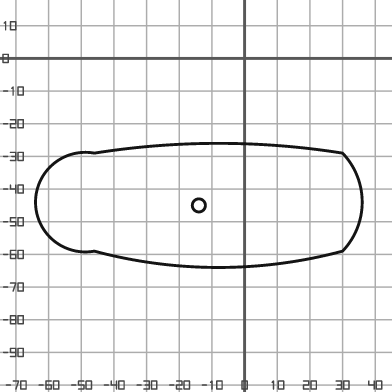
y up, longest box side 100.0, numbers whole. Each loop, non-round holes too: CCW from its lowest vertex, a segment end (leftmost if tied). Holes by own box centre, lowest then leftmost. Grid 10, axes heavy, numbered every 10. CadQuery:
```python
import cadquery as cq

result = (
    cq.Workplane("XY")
    .moveTo(-46.0, -59.0)
    .threePointArc((-8.0, -64.0), (30.0, -59.0))
    .threePointArc((36.0, -44.0), (30.0, -29.0))
    .threePointArc((-8.0, -26.0), (-46.0, -29.0))
    .threePointArc((-64.0, -44.0), (-46.0, -59.0))
    .close()
    .moveTo(-14.0, -45.0)
    .circle(2.0)
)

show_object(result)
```